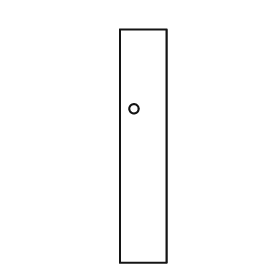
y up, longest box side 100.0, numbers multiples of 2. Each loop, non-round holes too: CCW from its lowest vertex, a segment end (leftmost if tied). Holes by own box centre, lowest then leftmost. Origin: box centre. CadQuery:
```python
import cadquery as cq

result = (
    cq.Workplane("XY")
    .moveTo(-10.0, -50.0)
    .lineTo(10.0, -50.0)
    .lineTo(10.0, 50.0)
    .lineTo(-10.0, 50.0)
    .close()
    .moveTo(-4.0, 16.0)
    .circle(2.0)
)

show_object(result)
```